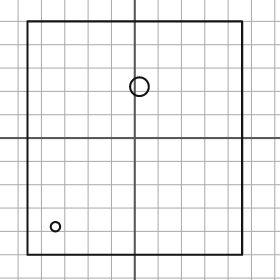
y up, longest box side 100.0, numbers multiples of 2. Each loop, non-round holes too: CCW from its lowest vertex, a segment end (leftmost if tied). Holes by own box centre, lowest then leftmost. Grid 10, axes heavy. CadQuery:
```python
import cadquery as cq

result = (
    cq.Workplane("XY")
    .moveTo(-46.0, -50.0)
    .lineTo(46.0, -50.0)
    .lineTo(46.0, 50.0)
    .lineTo(-46.0, 50.0)
    .close()
    .moveTo(-34.0, -38.0)
    .circle(2.0)
    .moveTo(2.0, 22.0)
    .circle(4.0)
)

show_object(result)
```